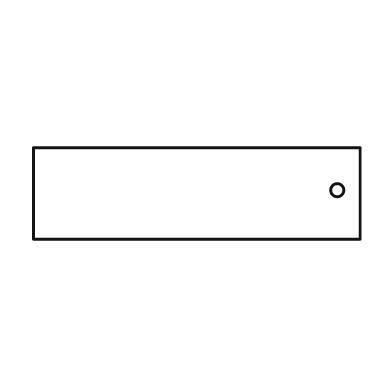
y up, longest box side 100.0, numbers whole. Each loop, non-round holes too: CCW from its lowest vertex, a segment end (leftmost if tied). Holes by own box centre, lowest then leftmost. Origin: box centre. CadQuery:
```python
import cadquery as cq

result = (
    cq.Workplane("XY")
    .moveTo(-50.0, -14.0)
    .lineTo(50.0, -14.0)
    .lineTo(50.0, 14.0)
    .lineTo(-50.0, 14.0)
    .close()
    .moveTo(43.0, 1.0)
    .circle(2.0)
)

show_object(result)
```